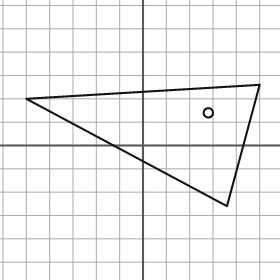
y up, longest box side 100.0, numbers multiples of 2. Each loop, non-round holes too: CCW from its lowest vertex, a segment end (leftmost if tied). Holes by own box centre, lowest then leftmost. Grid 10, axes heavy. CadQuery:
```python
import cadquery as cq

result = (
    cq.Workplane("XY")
    .moveTo(36.0, -26.0)
    .lineTo(50.0, 26.0)
    .lineTo(-50.0, 20.0)
    .close()
    .moveTo(28.0, 14.0)
    .circle(2.0)
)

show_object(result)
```